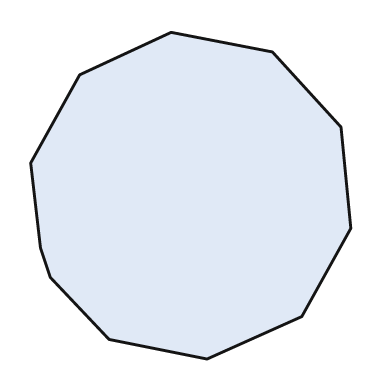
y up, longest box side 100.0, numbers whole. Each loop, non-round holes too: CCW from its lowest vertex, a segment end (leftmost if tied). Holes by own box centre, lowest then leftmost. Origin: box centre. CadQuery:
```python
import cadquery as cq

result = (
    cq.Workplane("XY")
    .moveTo(5.0, -50.0)
    .lineTo(34.0, -37.0)
    .lineTo(49.0, -10.0)
    .lineTo(46.0, 21.0)
    .lineTo(25.0, 44.0)
    .lineTo(-6.0, 50.0)
    .lineTo(-34.0, 37.0)
    .lineTo(-49.0, 10.0)
    .lineTo(-46.0, -16.0)
    .lineTo(-43.0, -25.0)
    .lineTo(-25.0, -44.0)
    .close()
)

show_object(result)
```